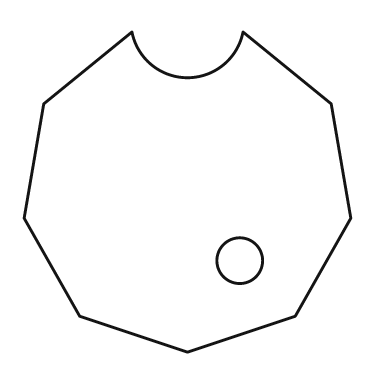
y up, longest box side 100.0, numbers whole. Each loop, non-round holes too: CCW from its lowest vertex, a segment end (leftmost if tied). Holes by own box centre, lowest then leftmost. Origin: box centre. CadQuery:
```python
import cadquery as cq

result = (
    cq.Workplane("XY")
    .moveTo(0.0, -49.0)
    .lineTo(33.0, -38.0)
    .lineTo(50.0, -8.0)
    .lineTo(44.0, 27.0)
    .lineTo(17.0, 49.0)
    .threePointArc((0.0, 35.0), (-17.0, 49.0))
    .lineTo(-44.0, 27.0)
    .lineTo(-50.0, -8.0)
    .lineTo(-33.0, -38.0)
    .close()
    .moveTo(16.0, -21.0)
    .circle(7.0)
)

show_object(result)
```